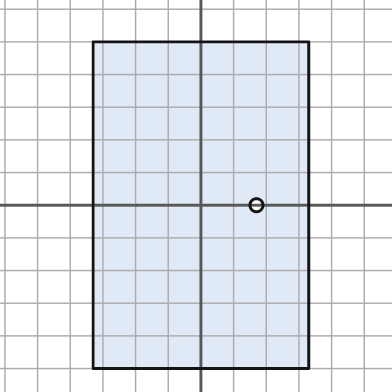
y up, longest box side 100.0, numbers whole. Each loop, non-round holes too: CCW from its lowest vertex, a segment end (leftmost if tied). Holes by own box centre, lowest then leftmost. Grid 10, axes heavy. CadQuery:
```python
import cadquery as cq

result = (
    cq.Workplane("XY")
    .moveTo(-33.0, -50.0)
    .lineTo(33.0, -50.0)
    .lineTo(33.0, 50.0)
    .lineTo(-33.0, 50.0)
    .close()
    .moveTo(17.0, 0.0)
    .circle(2.0)
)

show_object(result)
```